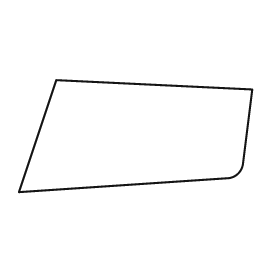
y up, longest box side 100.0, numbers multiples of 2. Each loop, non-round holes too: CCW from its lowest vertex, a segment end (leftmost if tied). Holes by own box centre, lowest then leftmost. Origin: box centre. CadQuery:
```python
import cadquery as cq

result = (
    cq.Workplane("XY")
    .moveTo(-50.0, -24.0)
    .lineTo(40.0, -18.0)
    .threePointArc((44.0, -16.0), (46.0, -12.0))
    .lineTo(50.0, 20.0)
    .lineTo(-34.0, 24.0)
    .close()
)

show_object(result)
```